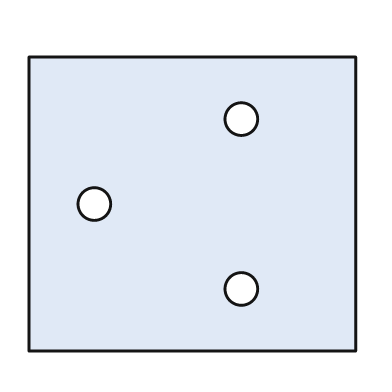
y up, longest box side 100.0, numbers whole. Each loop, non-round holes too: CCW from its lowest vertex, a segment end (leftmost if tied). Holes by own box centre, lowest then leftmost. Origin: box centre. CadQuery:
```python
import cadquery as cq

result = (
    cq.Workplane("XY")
    .moveTo(-50.0, -45.0)
    .lineTo(50.0, -45.0)
    .lineTo(50.0, 45.0)
    .lineTo(-50.0, 45.0)
    .close()
    .moveTo(15.0, -26.0)
    .circle(5.0)
    .moveTo(-30.0, 0.0)
    .circle(5.0)
    .moveTo(15.0, 26.0)
    .circle(5.0)
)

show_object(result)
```